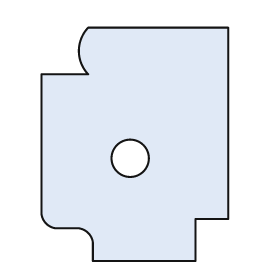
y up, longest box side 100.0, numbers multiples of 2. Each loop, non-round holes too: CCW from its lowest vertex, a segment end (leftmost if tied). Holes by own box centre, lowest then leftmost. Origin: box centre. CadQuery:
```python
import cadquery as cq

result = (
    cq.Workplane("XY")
    .moveTo(-18.0, -50.0)
    .lineTo(26.0, -50.0)
    .lineTo(26.0, -32.0)
    .lineTo(40.0, -32.0)
    .lineTo(40.0, 50.0)
    .lineTo(-20.0, 50.0)
    .threePointArc((-24.0, 40.0), (-20.0, 30.0))
    .lineTo(-40.0, 30.0)
    .lineTo(-40.0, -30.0)
    .threePointArc((-38.0, -34.0), (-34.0, -36.0))
    .lineTo(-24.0, -36.0)
    .threePointArc((-20.0, -38.0), (-18.0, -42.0))
    .close()
    .moveTo(-2.0, -6.0)
    .circle(8.0)
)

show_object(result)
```